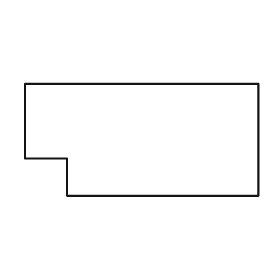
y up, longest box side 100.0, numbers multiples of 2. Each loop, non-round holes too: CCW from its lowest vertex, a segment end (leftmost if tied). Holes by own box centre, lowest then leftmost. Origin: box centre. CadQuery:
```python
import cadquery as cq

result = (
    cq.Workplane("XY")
    .moveTo(-32.0, -24.0)
    .lineTo(50.0, -24.0)
    .lineTo(50.0, 24.0)
    .lineTo(-50.0, 24.0)
    .lineTo(-50.0, -8.0)
    .lineTo(-32.0, -8.0)
    .close()
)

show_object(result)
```